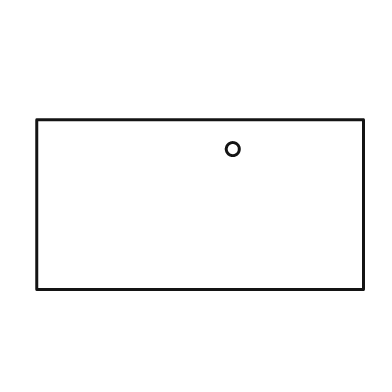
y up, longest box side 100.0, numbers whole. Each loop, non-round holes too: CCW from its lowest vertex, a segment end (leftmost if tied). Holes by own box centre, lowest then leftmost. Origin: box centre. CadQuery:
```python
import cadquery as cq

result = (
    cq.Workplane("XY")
    .moveTo(-50.0, -26.0)
    .lineTo(50.0, -26.0)
    .lineTo(50.0, 26.0)
    .lineTo(-50.0, 26.0)
    .close()
    .moveTo(10.0, 17.0)
    .circle(2.0)
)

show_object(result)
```